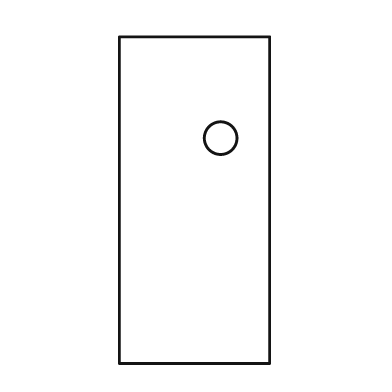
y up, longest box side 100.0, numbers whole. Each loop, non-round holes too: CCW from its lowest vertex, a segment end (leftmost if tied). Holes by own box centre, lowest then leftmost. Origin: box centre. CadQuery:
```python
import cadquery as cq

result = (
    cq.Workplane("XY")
    .moveTo(-23.0, -50.0)
    .lineTo(23.0, -50.0)
    .lineTo(23.0, 50.0)
    .lineTo(-23.0, 50.0)
    .close()
    .moveTo(8.0, 19.0)
    .circle(5.0)
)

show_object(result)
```